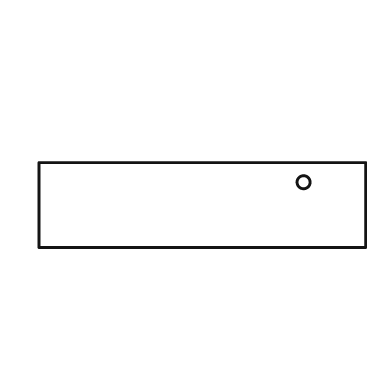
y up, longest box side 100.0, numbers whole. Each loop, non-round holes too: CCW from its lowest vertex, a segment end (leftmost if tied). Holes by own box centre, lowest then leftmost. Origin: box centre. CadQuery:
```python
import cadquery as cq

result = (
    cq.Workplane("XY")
    .moveTo(-50.0, -13.0)
    .lineTo(50.0, -13.0)
    .lineTo(50.0, 13.0)
    .lineTo(-50.0, 13.0)
    .close()
    .moveTo(31.0, 7.0)
    .circle(2.0)
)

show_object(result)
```